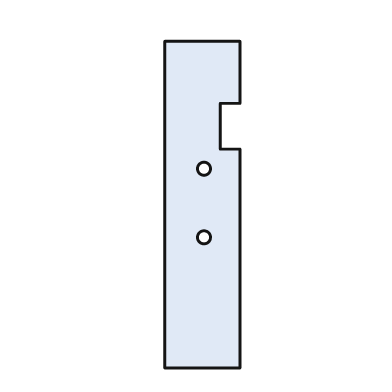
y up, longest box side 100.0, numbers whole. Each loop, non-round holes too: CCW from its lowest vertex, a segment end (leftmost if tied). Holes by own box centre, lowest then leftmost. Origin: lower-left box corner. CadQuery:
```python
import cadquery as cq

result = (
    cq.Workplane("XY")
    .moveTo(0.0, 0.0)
    .lineTo(23.0, 0.0)
    .lineTo(23.0, 67.0)
    .lineTo(17.0, 67.0)
    .lineTo(17.0, 81.0)
    .lineTo(23.0, 81.0)
    .lineTo(23.0, 100.0)
    .lineTo(0.0, 100.0)
    .close()
    .moveTo(12.0, 40.0)
    .circle(2.0)
    .moveTo(12.0, 61.0)
    .circle(2.0)
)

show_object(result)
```